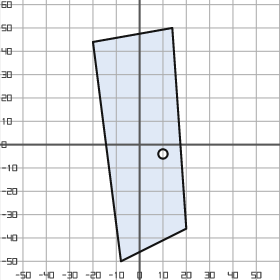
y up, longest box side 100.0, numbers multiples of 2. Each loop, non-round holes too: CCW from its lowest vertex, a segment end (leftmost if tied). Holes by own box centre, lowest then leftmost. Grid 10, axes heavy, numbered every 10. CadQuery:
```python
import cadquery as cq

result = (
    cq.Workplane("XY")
    .moveTo(-8.0, -50.0)
    .lineTo(20.0, -36.0)
    .lineTo(14.0, 50.0)
    .lineTo(-20.0, 44.0)
    .close()
    .moveTo(10.0, -4.0)
    .circle(2.0)
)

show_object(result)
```